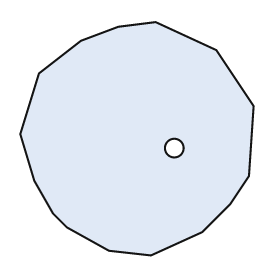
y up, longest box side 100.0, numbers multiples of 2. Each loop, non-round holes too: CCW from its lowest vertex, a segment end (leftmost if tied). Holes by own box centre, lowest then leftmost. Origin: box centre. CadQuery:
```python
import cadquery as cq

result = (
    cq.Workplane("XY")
    .moveTo(6.0, -50.0)
    .lineTo(28.0, -40.0)
    .lineTo(40.0, -28.0)
    .lineTo(48.0, -16.0)
    .lineTo(50.0, 14.0)
    .lineTo(34.0, 38.0)
    .lineTo(8.0, 50.0)
    .lineTo(-8.0, 48.0)
    .lineTo(-24.0, 42.0)
    .lineTo(-42.0, 28.0)
    .lineTo(-50.0, 2.0)
    .lineTo(-44.0, -18.0)
    .lineTo(-36.0, -32.0)
    .lineTo(-30.0, -38.0)
    .lineTo(-12.0, -48.0)
    .close()
    .moveTo(16.0, -4.0)
    .circle(4.0)
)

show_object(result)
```